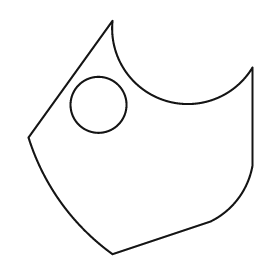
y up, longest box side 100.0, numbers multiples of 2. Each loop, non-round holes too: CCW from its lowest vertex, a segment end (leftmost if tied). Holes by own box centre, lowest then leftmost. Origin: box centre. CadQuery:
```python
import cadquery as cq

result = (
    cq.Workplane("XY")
    .moveTo(-12.0, -50.0)
    .lineTo(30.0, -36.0)
    .threePointArc((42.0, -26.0), (48.0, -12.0))
    .lineTo(48.0, 30.0)
    .threePointArc((10.0, 16.0), (-12.0, 50.0))
    .lineTo(-48.0, 0.0)
    .threePointArc((-34.0, -28.0), (-12.0, -50.0))
    .close()
    .moveTo(-18.0, 14.0)
    .circle(12.0)
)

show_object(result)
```